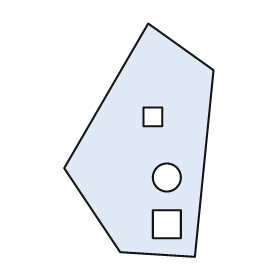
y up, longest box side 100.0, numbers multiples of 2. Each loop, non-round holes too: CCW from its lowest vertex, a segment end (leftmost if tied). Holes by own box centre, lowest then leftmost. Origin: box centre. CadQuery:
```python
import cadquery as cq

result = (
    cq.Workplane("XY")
    .moveTo(24.0, -50.0)
    .lineTo(32.0, 30.0)
    .lineTo(4.0, 50.0)
    .lineTo(-32.0, -12.0)
    .lineTo(-8.0, -48.0)
    .close()
    .moveTo(6.0, -42.0)
    .lineTo(18.0, -42.0)
    .lineTo(18.0, -30.0)
    .lineTo(6.0, -30.0)
    .close()
    .moveTo(12.0, -16.0)
    .circle(6.0)
    .moveTo(2.0, 6.0)
    .lineTo(10.0, 6.0)
    .lineTo(10.0, 14.0)
    .lineTo(2.0, 14.0)
    .close()
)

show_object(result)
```